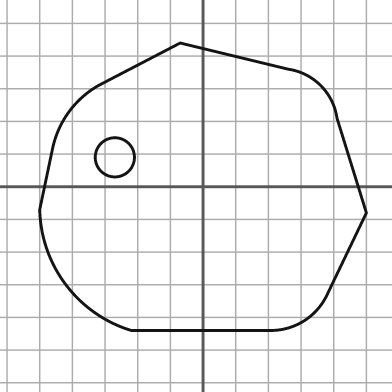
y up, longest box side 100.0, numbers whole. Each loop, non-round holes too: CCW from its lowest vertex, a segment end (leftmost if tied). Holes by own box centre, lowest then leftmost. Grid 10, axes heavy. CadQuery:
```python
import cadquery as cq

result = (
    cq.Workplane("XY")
    .moveTo(-22.0, -44.0)
    .lineTo(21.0, -44.0)
    .threePointArc((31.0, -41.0), (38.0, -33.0))
    .lineTo(50.0, -8.0)
    .lineTo(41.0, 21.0)
    .threePointArc((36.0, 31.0), (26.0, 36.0))
    .lineTo(-7.0, 44.0)
    .lineTo(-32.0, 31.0)
    .threePointArc((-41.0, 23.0), (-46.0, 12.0))
    .lineTo(-50.0, -7.0)
    .threePointArc((-42.0, -30.0), (-22.0, -44.0))
    .close()
    .moveTo(-27.0, 9.0)
    .circle(6.0)
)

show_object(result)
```